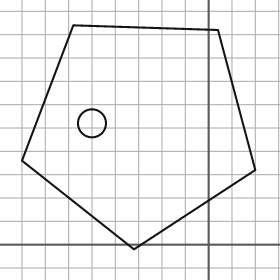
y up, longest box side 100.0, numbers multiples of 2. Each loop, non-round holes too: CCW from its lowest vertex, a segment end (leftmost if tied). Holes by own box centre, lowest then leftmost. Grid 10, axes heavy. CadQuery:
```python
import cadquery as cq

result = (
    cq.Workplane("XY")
    .moveTo(-32.0, -2.0)
    .lineTo(20.0, 32.0)
    .lineTo(4.0, 92.0)
    .lineTo(-58.0, 94.0)
    .lineTo(-80.0, 36.0)
    .close()
    .moveTo(-50.0, 52.0)
    .circle(6.0)
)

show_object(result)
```